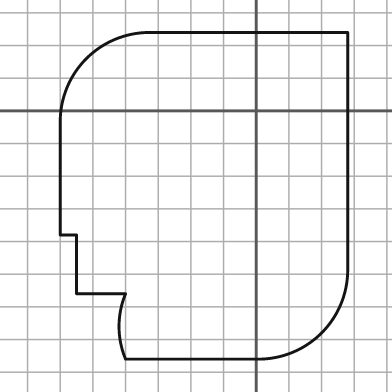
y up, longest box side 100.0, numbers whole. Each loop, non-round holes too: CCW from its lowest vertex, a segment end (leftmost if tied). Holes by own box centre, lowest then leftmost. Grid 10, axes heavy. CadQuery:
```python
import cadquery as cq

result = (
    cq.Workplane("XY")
    .moveTo(-40.0, -76.0)
    .lineTo(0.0, -76.0)
    .threePointArc((20.0, -68.0), (28.0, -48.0))
    .lineTo(28.0, 24.0)
    .lineTo(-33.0, 24.0)
    .threePointArc((-52.0, 16.0), (-60.0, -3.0))
    .lineTo(-60.0, -38.0)
    .lineTo(-55.0, -38.0)
    .lineTo(-55.0, -56.0)
    .lineTo(-40.0, -56.0)
    .threePointArc((-42.0, -66.0), (-40.0, -76.0))
    .close()
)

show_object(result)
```